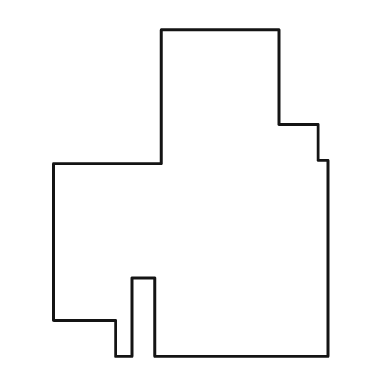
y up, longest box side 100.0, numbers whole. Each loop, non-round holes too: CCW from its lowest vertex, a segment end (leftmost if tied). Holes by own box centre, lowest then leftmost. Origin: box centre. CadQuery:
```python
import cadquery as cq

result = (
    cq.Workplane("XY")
    .moveTo(-23.0, -50.0)
    .lineTo(-18.0, -50.0)
    .lineTo(-18.0, -26.0)
    .lineTo(-11.0, -26.0)
    .lineTo(-11.0, -50.0)
    .lineTo(42.0, -50.0)
    .lineTo(42.0, 10.0)
    .lineTo(39.0, 10.0)
    .lineTo(39.0, 21.0)
    .lineTo(27.0, 21.0)
    .lineTo(27.0, 50.0)
    .lineTo(-9.0, 50.0)
    .lineTo(-9.0, 9.0)
    .lineTo(-42.0, 9.0)
    .lineTo(-42.0, -39.0)
    .lineTo(-23.0, -39.0)
    .close()
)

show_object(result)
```